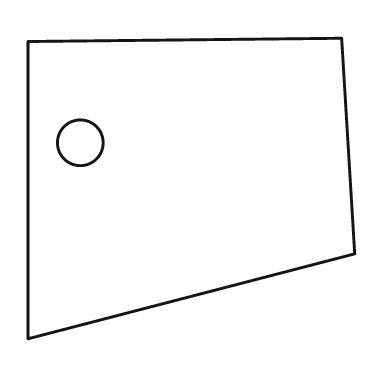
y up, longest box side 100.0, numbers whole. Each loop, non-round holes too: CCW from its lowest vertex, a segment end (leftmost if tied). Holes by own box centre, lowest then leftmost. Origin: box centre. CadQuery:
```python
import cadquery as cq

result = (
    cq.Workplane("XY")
    .moveTo(-50.0, -46.0)
    .lineTo(50.0, -20.0)
    .lineTo(46.0, 46.0)
    .lineTo(-50.0, 45.0)
    .close()
    .moveTo(-34.0, 14.0)
    .circle(7.0)
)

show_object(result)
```